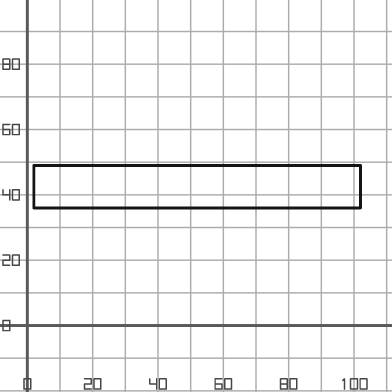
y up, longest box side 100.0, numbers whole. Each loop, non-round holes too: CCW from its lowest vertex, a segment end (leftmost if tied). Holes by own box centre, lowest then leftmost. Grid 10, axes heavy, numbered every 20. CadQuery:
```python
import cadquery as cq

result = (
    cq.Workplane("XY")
    .moveTo(2.0, 36.0)
    .lineTo(102.0, 36.0)
    .lineTo(102.0, 49.0)
    .lineTo(2.0, 49.0)
    .close()
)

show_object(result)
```